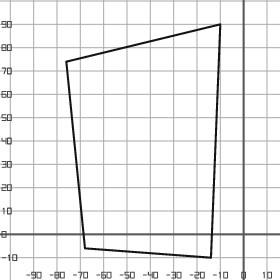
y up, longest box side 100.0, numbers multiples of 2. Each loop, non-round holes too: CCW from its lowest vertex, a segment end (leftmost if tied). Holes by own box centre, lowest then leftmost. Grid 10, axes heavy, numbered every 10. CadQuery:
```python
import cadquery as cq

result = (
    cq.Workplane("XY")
    .moveTo(-14.0, -10.0)
    .lineTo(-10.0, 90.0)
    .lineTo(-76.0, 74.0)
    .lineTo(-68.0, -6.0)
    .close()
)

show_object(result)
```